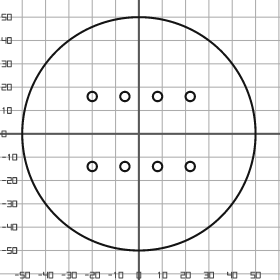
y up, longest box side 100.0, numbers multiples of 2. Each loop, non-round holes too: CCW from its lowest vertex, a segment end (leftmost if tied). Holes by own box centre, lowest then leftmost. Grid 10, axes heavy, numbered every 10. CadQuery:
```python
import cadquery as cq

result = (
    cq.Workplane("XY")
    .moveTo(0.0, 0.0)
    .circle(50.0)
    .moveTo(-20.0, -14.0)
    .circle(2.0)
    .moveTo(-6.0, -14.0)
    .circle(2.0)
    .moveTo(8.0, -14.0)
    .circle(2.0)
    .moveTo(22.0, -14.0)
    .circle(2.0)
    .moveTo(-20.0, 16.0)
    .circle(2.0)
    .moveTo(-6.0, 16.0)
    .circle(2.0)
    .moveTo(8.0, 16.0)
    .circle(2.0)
    .moveTo(22.0, 16.0)
    .circle(2.0)
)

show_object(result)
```